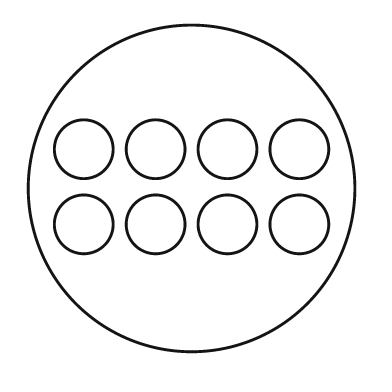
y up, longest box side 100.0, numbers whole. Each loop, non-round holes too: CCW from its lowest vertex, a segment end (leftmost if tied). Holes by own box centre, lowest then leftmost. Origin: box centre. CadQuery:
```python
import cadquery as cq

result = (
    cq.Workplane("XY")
    .moveTo(0.0, 0.0)
    .circle(50.0)
    .moveTo(-33.0, -11.0)
    .circle(9.0)
    .moveTo(-11.0, -11.0)
    .circle(9.0)
    .moveTo(11.0, -11.0)
    .circle(9.0)
    .moveTo(33.0, -11.0)
    .circle(9.0)
    .moveTo(-33.0, 12.0)
    .circle(9.0)
    .moveTo(-11.0, 12.0)
    .circle(9.0)
    .moveTo(11.0, 12.0)
    .circle(9.0)
    .moveTo(33.0, 12.0)
    .circle(9.0)
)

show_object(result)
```